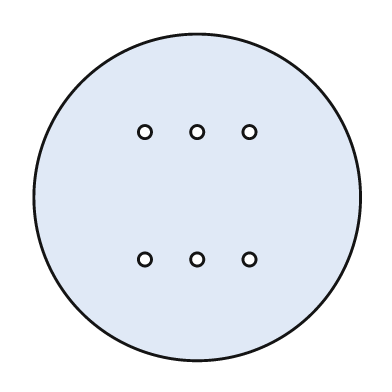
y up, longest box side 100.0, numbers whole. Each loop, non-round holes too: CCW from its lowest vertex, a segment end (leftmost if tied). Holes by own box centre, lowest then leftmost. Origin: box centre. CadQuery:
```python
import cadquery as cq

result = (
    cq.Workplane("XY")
    .moveTo(0.0, 0.0)
    .circle(50.0)
    .moveTo(-16.0, -19.0)
    .circle(2.0)
    .moveTo(0.0, -19.0)
    .circle(2.0)
    .moveTo(16.0, -19.0)
    .circle(2.0)
    .moveTo(-16.0, 20.0)
    .circle(2.0)
    .moveTo(0.0, 20.0)
    .circle(2.0)
    .moveTo(16.0, 20.0)
    .circle(2.0)
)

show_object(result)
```